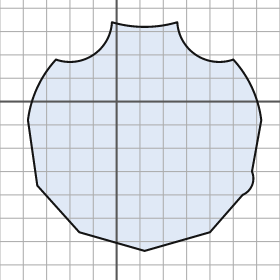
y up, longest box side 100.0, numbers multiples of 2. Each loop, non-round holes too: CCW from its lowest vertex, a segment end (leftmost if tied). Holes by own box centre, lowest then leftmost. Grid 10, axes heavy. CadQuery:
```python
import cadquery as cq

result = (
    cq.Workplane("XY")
    .moveTo(12.0, -64.0)
    .lineTo(40.0, -56.0)
    .lineTo(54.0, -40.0)
    .threePointArc((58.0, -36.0), (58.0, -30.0))
    .lineTo(62.0, -8.0)
    .threePointArc((58.0, 6.0), (50.0, 18.0))
    .threePointArc((34.0, 20.0), (26.0, 34.0))
    .threePointArc((12.0, 32.0), (-2.0, 34.0))
    .threePointArc((-10.0, 20.0), (-26.0, 18.0))
    .threePointArc((-34.0, 6.0), (-38.0, -8.0))
    .lineTo(-34.0, -36.0)
    .lineTo(-16.0, -56.0)
    .close()
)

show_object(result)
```